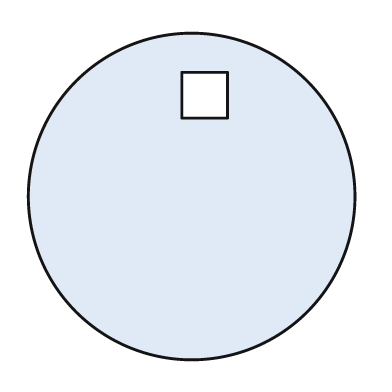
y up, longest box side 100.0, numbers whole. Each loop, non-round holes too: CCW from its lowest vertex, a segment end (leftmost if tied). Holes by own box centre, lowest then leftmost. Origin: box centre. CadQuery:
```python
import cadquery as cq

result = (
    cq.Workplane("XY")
    .moveTo(0.0, 0.0)
    .circle(50.0)
    .moveTo(-3.0, 24.0)
    .lineTo(11.0, 24.0)
    .lineTo(11.0, 38.0)
    .lineTo(-3.0, 38.0)
    .close()
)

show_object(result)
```